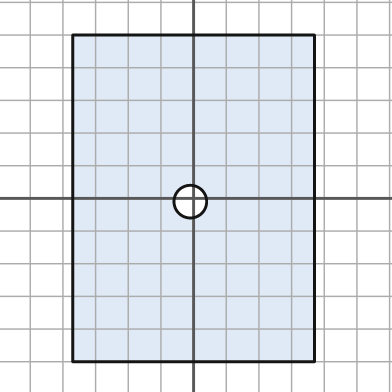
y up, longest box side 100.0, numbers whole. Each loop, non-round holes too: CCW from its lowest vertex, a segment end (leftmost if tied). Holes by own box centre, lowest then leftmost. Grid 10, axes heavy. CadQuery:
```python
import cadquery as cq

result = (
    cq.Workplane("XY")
    .moveTo(-37.0, -50.0)
    .lineTo(37.0, -50.0)
    .lineTo(37.0, 50.0)
    .lineTo(-37.0, 50.0)
    .close()
    .moveTo(-1.0, -1.0)
    .circle(5.0)
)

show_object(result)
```